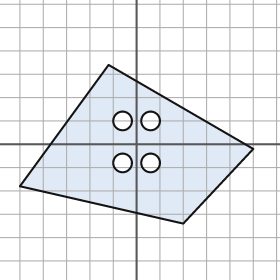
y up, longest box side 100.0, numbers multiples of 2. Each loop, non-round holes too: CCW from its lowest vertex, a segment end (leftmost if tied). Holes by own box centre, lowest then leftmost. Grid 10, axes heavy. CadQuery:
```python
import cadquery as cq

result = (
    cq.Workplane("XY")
    .moveTo(20.0, -34.0)
    .lineTo(50.0, -2.0)
    .lineTo(-12.0, 34.0)
    .lineTo(-50.0, -18.0)
    .close()
    .moveTo(-6.0, -8.0)
    .circle(4.0)
    .moveTo(6.0, -8.0)
    .circle(4.0)
    .moveTo(-6.0, 10.0)
    .circle(4.0)
    .moveTo(6.0, 10.0)
    .circle(4.0)
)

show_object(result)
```